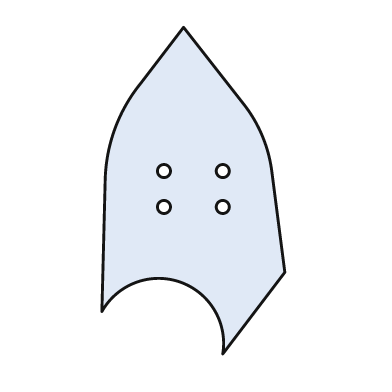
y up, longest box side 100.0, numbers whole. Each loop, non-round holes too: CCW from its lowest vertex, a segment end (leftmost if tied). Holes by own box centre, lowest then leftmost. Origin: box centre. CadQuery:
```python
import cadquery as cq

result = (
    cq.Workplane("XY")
    .moveTo(9.0, -50.0)
    .lineTo(28.0, -25.0)
    .lineTo(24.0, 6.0)
    .threePointArc((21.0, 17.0), (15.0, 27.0))
    .lineTo(-3.0, 50.0)
    .lineTo(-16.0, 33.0)
    .threePointArc((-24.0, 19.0), (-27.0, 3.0))
    .lineTo(-28.0, -37.0)
    .threePointArc((-4.0, -28.0), (9.0, -50.0))
    .close()
    .moveTo(-9.0, -5.0)
    .circle(2.0)
    .moveTo(9.0, -5.0)
    .circle(2.0)
    .moveTo(-9.0, 6.0)
    .circle(2.0)
    .moveTo(9.0, 6.0)
    .circle(2.0)
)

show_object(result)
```